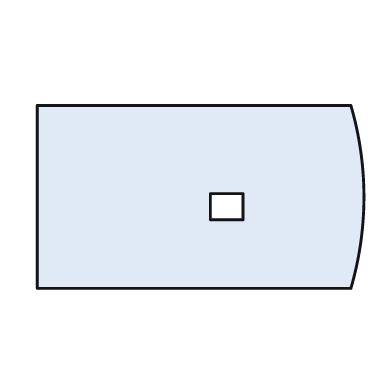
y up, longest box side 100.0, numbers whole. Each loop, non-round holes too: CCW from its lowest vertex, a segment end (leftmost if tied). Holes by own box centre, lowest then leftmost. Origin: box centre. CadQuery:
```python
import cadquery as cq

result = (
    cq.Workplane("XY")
    .moveTo(-50.0, -28.0)
    .lineTo(46.0, -28.0)
    .threePointArc((50.0, 0.0), (46.0, 28.0))
    .lineTo(-50.0, 28.0)
    .close()
    .moveTo(3.0, -7.0)
    .lineTo(13.0, -7.0)
    .lineTo(13.0, 1.0)
    .lineTo(3.0, 1.0)
    .close()
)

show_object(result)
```